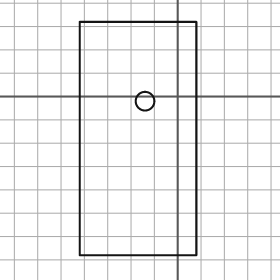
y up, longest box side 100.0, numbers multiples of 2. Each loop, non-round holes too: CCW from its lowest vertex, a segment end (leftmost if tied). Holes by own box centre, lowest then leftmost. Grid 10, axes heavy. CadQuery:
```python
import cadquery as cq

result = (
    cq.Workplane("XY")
    .moveTo(-42.0, -68.0)
    .lineTo(8.0, -68.0)
    .lineTo(8.0, 32.0)
    .lineTo(-42.0, 32.0)
    .close()
    .moveTo(-14.0, -2.0)
    .circle(4.0)
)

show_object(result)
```